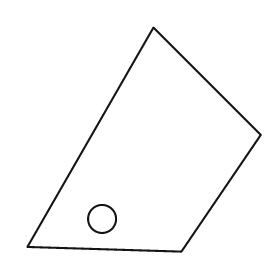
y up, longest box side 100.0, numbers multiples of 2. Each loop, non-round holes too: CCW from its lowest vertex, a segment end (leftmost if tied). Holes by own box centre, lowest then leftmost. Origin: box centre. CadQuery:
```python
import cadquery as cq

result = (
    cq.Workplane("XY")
    .moveTo(16.0, -48.0)
    .lineTo(50.0, 2.0)
    .lineTo(4.0, 48.0)
    .lineTo(-50.0, -46.0)
    .close()
    .moveTo(-18.0, -34.0)
    .circle(6.0)
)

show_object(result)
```